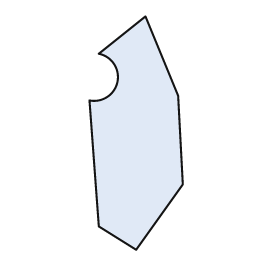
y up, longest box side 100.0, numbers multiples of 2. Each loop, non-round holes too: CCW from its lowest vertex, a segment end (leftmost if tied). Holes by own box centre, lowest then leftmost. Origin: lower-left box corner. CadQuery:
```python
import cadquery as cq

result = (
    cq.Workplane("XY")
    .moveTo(20.0, 0.0)
    .lineTo(40.0, 28.0)
    .lineTo(38.0, 66.0)
    .lineTo(24.0, 100.0)
    .lineTo(4.0, 84.0)
    .threePointArc((12.0, 72.0), (0.0, 64.0))
    .lineTo(4.0, 10.0)
    .close()
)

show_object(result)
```